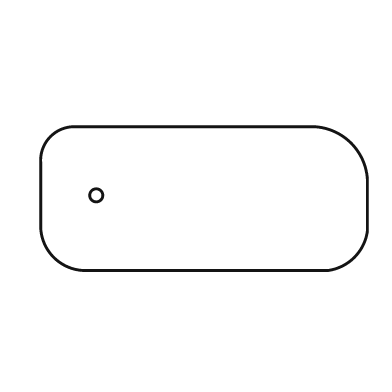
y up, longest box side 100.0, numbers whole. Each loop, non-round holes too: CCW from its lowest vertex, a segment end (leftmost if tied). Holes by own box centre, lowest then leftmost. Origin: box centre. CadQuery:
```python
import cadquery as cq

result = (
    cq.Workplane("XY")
    .moveTo(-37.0, -22.0)
    .lineTo(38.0, -22.0)
    .threePointArc((46.0, -18.0), (50.0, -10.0))
    .lineTo(50.0, 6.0)
    .threePointArc((45.0, 17.0), (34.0, 22.0))
    .lineTo(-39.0, 22.0)
    .threePointArc((-47.0, 19.0), (-50.0, 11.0))
    .lineTo(-50.0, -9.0)
    .threePointArc((-46.0, -18.0), (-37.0, -22.0))
    .close()
    .moveTo(-33.0, 1.0)
    .circle(2.0)
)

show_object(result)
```